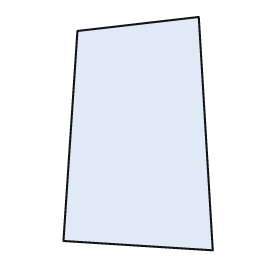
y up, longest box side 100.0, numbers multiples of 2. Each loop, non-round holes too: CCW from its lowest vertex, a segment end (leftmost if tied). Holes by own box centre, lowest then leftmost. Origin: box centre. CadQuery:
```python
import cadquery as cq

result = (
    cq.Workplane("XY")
    .moveTo(32.0, -50.0)
    .lineTo(26.0, 50.0)
    .lineTo(-26.0, 44.0)
    .lineTo(-32.0, -46.0)
    .close()
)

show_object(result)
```